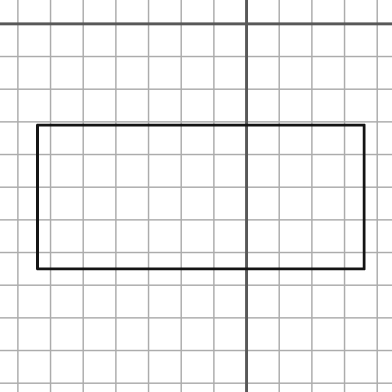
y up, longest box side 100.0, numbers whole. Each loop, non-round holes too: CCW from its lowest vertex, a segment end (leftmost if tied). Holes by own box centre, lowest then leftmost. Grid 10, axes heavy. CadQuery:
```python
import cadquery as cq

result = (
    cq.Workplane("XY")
    .moveTo(-64.0, -75.0)
    .lineTo(36.0, -75.0)
    .lineTo(36.0, -31.0)
    .lineTo(-64.0, -31.0)
    .close()
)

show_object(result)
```